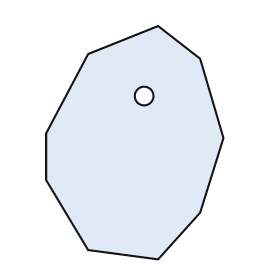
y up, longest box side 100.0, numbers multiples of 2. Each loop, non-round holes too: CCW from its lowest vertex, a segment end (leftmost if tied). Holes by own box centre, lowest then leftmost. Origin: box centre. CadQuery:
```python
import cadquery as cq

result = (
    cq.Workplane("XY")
    .moveTo(10.0, -50.0)
    .lineTo(28.0, -30.0)
    .lineTo(38.0, 2.0)
    .lineTo(28.0, 36.0)
    .lineTo(10.0, 50.0)
    .lineTo(-20.0, 38.0)
    .lineTo(-38.0, 4.0)
    .lineTo(-38.0, -16.0)
    .lineTo(-20.0, -46.0)
    .close()
    .moveTo(4.0, 20.0)
    .circle(4.0)
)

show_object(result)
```